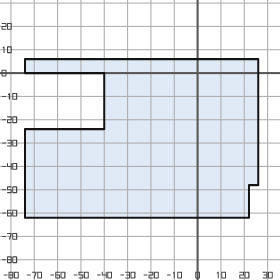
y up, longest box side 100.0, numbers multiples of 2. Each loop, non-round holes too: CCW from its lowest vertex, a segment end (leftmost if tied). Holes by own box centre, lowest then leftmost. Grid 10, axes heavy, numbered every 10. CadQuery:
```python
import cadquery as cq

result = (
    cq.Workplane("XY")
    .moveTo(-74.0, -62.0)
    .lineTo(22.0, -62.0)
    .lineTo(22.0, -48.0)
    .lineTo(26.0, -48.0)
    .lineTo(26.0, 6.0)
    .lineTo(-74.0, 6.0)
    .lineTo(-74.0, 0.0)
    .lineTo(-40.0, 0.0)
    .lineTo(-40.0, -24.0)
    .lineTo(-74.0, -24.0)
    .close()
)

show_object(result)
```